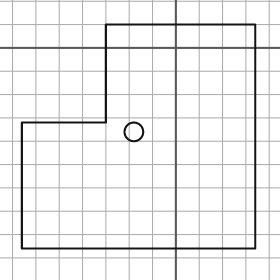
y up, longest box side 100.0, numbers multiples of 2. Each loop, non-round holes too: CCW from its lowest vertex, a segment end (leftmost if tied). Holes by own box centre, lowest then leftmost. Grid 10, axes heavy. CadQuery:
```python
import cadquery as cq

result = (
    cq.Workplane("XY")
    .moveTo(-66.0, -86.0)
    .lineTo(34.0, -86.0)
    .lineTo(34.0, 10.0)
    .lineTo(-30.0, 10.0)
    .lineTo(-30.0, -32.0)
    .lineTo(-66.0, -32.0)
    .close()
    .moveTo(-18.0, -36.0)
    .circle(4.0)
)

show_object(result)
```